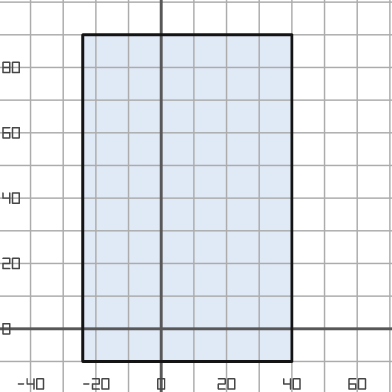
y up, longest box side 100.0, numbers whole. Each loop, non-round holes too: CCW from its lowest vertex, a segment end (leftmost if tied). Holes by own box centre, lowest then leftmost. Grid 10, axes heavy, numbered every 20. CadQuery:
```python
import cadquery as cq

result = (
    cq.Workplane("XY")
    .moveTo(-24.0, -10.0)
    .lineTo(40.0, -10.0)
    .lineTo(40.0, 90.0)
    .lineTo(-24.0, 90.0)
    .close()
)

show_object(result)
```